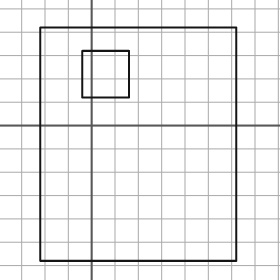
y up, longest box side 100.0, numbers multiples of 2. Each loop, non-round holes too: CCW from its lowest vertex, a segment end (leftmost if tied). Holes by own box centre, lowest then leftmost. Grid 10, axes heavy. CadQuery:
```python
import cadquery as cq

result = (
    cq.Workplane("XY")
    .moveTo(-22.0, -58.0)
    .lineTo(62.0, -58.0)
    .lineTo(62.0, 42.0)
    .lineTo(-22.0, 42.0)
    .close()
    .moveTo(-4.0, 12.0)
    .lineTo(16.0, 12.0)
    .lineTo(16.0, 32.0)
    .lineTo(-4.0, 32.0)
    .close()
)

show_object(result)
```